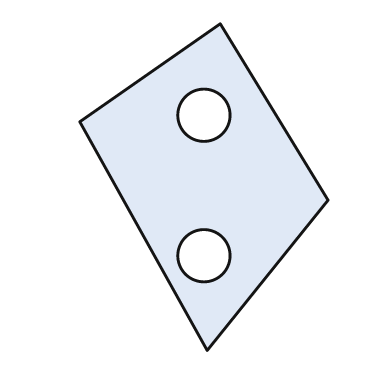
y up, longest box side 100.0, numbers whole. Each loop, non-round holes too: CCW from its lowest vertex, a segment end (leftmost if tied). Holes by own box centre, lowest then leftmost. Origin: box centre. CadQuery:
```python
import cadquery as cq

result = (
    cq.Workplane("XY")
    .moveTo(1.0, -50.0)
    .lineTo(38.0, -4.0)
    .lineTo(5.0, 50.0)
    .lineTo(-38.0, 20.0)
    .close()
    .moveTo(0.0, -21.0)
    .circle(8.0)
    .moveTo(0.0, 22.0)
    .circle(8.0)
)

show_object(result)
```